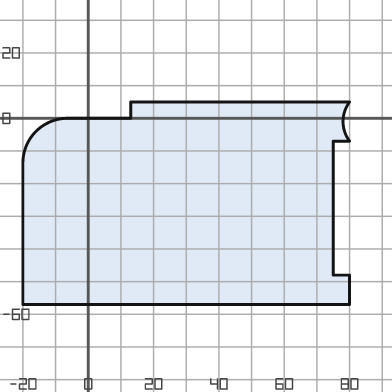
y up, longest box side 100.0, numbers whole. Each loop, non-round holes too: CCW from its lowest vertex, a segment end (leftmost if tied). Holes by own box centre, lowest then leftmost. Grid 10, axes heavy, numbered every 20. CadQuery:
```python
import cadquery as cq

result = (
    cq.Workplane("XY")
    .moveTo(-20.0, -57.0)
    .lineTo(80.0, -57.0)
    .lineTo(80.0, -48.0)
    .lineTo(75.0, -48.0)
    .lineTo(75.0, -7.0)
    .lineTo(80.0, -7.0)
    .threePointArc((78.0, -1.0), (80.0, 5.0))
    .lineTo(13.0, 5.0)
    .lineTo(13.0, 0.0)
    .lineTo(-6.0, 0.0)
    .threePointArc((-16.0, -4.0), (-20.0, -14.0))
    .close()
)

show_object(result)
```